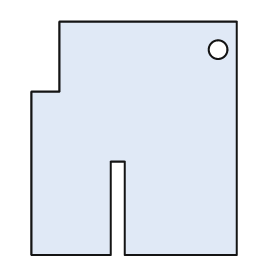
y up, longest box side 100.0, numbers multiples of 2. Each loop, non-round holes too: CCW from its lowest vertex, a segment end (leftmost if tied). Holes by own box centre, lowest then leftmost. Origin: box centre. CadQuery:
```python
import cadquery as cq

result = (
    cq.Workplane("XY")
    .moveTo(-44.0, -50.0)
    .lineTo(-10.0, -50.0)
    .lineTo(-10.0, -10.0)
    .lineTo(-4.0, -10.0)
    .lineTo(-4.0, -50.0)
    .lineTo(44.0, -50.0)
    .lineTo(44.0, 50.0)
    .lineTo(-32.0, 50.0)
    .lineTo(-32.0, 20.0)
    .lineTo(-44.0, 20.0)
    .close()
    .moveTo(36.0, 38.0)
    .circle(4.0)
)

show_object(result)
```